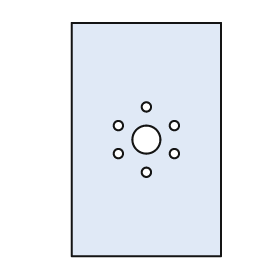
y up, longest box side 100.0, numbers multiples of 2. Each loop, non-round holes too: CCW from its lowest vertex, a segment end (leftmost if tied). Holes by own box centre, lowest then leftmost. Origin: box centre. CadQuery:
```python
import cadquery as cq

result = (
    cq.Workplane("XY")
    .moveTo(-32.0, -50.0)
    .lineTo(32.0, -50.0)
    .lineTo(32.0, 50.0)
    .lineTo(-32.0, 50.0)
    .close()
    .moveTo(0.0, -14.0)
    .circle(2.0)
    .moveTo(-12.0, -6.0)
    .circle(2.0)
    .moveTo(12.0, -6.0)
    .circle(2.0)
    .moveTo(0.0, 0.0)
    .circle(6.0)
    .moveTo(-12.0, 6.0)
    .circle(2.0)
    .moveTo(12.0, 6.0)
    .circle(2.0)
    .moveTo(0.0, 14.0)
    .circle(2.0)
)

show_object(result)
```